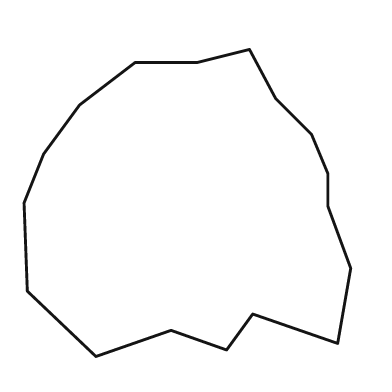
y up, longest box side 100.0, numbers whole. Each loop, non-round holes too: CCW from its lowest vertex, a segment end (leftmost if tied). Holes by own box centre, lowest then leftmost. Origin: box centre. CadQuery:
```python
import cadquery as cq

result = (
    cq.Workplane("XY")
    .moveTo(-28.0, -47.0)
    .lineTo(-5.0, -39.0)
    .lineTo(12.0, -45.0)
    .lineTo(20.0, -34.0)
    .lineTo(46.0, -43.0)
    .lineTo(50.0, -20.0)
    .lineTo(43.0, -1.0)
    .lineTo(43.0, 9.0)
    .lineTo(38.0, 21.0)
    .lineTo(27.0, 32.0)
    .lineTo(19.0, 47.0)
    .lineTo(3.0, 43.0)
    .lineTo(-16.0, 43.0)
    .lineTo(-33.0, 30.0)
    .lineTo(-44.0, 15.0)
    .lineTo(-50.0, 0.0)
    .lineTo(-49.0, -27.0)
    .close()
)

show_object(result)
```